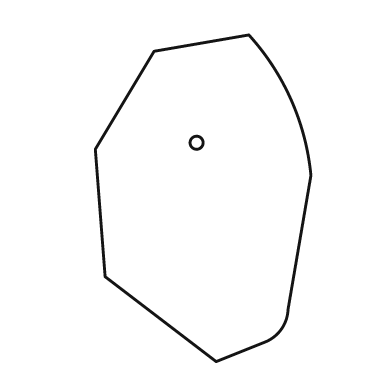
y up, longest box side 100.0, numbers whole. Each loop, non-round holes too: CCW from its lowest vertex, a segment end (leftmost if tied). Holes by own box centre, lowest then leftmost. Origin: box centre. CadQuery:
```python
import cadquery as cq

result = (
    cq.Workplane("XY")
    .moveTo(4.0, -50.0)
    .lineTo(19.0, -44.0)
    .threePointArc((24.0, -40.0), (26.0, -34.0))
    .lineTo(33.0, 7.0)
    .threePointArc((27.0, 30.0), (14.0, 50.0))
    .lineTo(-15.0, 45.0)
    .lineTo(-33.0, 15.0)
    .lineTo(-30.0, -24.0)
    .close()
    .moveTo(-2.0, 17.0)
    .circle(2.0)
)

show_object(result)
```